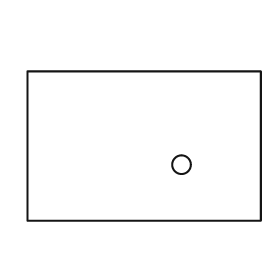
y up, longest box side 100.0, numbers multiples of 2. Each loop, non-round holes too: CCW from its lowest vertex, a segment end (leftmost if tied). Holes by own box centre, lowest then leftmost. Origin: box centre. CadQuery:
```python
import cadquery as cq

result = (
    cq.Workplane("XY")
    .moveTo(-50.0, -32.0)
    .lineTo(50.0, -32.0)
    .lineTo(50.0, 32.0)
    .lineTo(-50.0, 32.0)
    .close()
    .moveTo(16.0, -8.0)
    .circle(4.0)
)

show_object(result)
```